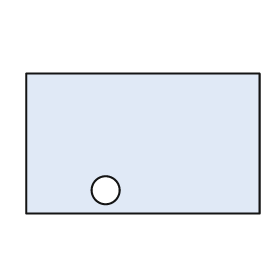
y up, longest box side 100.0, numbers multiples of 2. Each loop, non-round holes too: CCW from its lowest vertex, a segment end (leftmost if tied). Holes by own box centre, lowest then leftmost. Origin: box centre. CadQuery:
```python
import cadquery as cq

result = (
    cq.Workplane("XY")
    .moveTo(-50.0, -30.0)
    .lineTo(50.0, -30.0)
    .lineTo(50.0, 30.0)
    .lineTo(-50.0, 30.0)
    .close()
    .moveTo(-16.0, -20.0)
    .circle(6.0)
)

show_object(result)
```